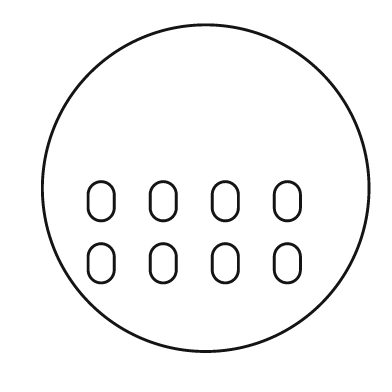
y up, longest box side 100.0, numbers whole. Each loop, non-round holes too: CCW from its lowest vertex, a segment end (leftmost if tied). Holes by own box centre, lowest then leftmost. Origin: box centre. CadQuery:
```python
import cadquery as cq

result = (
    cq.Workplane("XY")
    .moveTo(0.0, 0.0)
    .circle(50.0)
    .moveTo(-36.0, -25.0)
    .threePointArc((-32.0, -29.0), (-28.0, -25.0))
    .lineTo(-28.0, -21.0)
    .threePointArc((-32.0, -17.0), (-36.0, -21.0))
    .close()
    .moveTo(-17.0, -25.0)
    .threePointArc((-13.0, -29.0), (-9.0, -25.0))
    .lineTo(-9.0, -21.0)
    .threePointArc((-13.0, -17.0), (-17.0, -21.0))
    .close()
    .moveTo(2.0, -25.0)
    .threePointArc((6.0, -29.0), (10.0, -25.0))
    .lineTo(10.0, -21.0)
    .threePointArc((6.0, -17.0), (2.0, -21.0))
    .close()
    .moveTo(21.0, -25.0)
    .threePointArc((25.0, -29.0), (29.0, -25.0))
    .lineTo(29.0, -21.0)
    .threePointArc((25.0, -17.0), (21.0, -21.0))
    .close()
    .moveTo(-36.0, -6.0)
    .threePointArc((-32.0, -10.0), (-28.0, -6.0))
    .lineTo(-28.0, -2.0)
    .threePointArc((-32.0, 2.0), (-36.0, -2.0))
    .close()
    .moveTo(-17.0, -6.0)
    .threePointArc((-13.0, -10.0), (-9.0, -6.0))
    .lineTo(-9.0, -2.0)
    .threePointArc((-13.0, 2.0), (-17.0, -2.0))
    .close()
    .moveTo(2.0, -6.0)
    .threePointArc((6.0, -10.0), (10.0, -6.0))
    .lineTo(10.0, -2.0)
    .threePointArc((6.0, 2.0), (2.0, -2.0))
    .close()
    .moveTo(21.0, -6.0)
    .threePointArc((25.0, -10.0), (29.0, -6.0))
    .lineTo(29.0, -2.0)
    .threePointArc((25.0, 2.0), (21.0, -2.0))
    .close()
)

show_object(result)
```